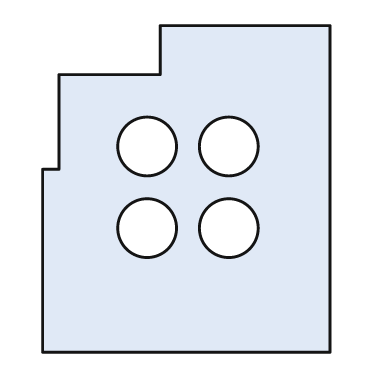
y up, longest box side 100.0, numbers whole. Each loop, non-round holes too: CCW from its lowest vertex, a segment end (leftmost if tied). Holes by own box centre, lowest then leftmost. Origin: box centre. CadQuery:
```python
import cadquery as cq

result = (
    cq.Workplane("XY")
    .moveTo(-44.0, -50.0)
    .lineTo(44.0, -50.0)
    .lineTo(44.0, 50.0)
    .lineTo(-8.0, 50.0)
    .lineTo(-8.0, 35.0)
    .lineTo(-39.0, 35.0)
    .lineTo(-39.0, 6.0)
    .lineTo(-44.0, 6.0)
    .close()
    .moveTo(-12.0, -12.0)
    .circle(9.0)
    .moveTo(13.0, -12.0)
    .circle(9.0)
    .moveTo(-12.0, 13.0)
    .circle(9.0)
    .moveTo(13.0, 13.0)
    .circle(9.0)
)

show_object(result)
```